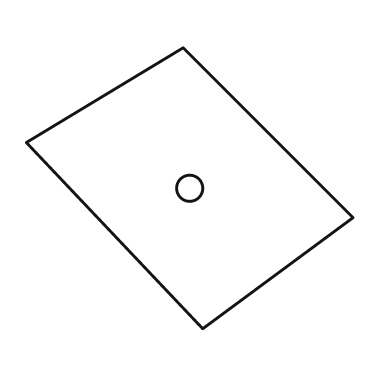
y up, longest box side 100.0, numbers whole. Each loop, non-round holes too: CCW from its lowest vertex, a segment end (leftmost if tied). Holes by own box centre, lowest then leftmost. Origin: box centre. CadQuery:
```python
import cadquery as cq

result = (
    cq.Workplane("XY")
    .moveTo(4.0, -43.0)
    .lineTo(50.0, -9.0)
    .lineTo(-2.0, 43.0)
    .lineTo(-50.0, 14.0)
    .close()
    .moveTo(0.0, 0.0)
    .circle(4.0)
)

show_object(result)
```